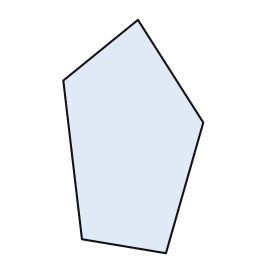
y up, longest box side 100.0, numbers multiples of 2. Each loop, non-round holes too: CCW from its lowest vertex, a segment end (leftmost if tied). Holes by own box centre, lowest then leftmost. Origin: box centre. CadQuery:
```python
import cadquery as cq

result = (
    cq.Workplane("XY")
    .moveTo(14.0, -50.0)
    .lineTo(30.0, 6.0)
    .lineTo(2.0, 50.0)
    .lineTo(-30.0, 24.0)
    .lineTo(-22.0, -44.0)
    .close()
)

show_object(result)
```